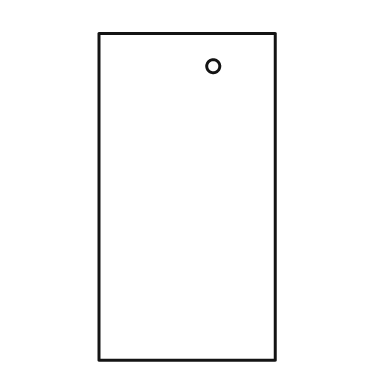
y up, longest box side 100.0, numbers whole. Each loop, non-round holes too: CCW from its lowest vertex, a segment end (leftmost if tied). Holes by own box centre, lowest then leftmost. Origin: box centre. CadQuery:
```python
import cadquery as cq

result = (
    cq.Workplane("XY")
    .moveTo(-27.0, -50.0)
    .lineTo(27.0, -50.0)
    .lineTo(27.0, 50.0)
    .lineTo(-27.0, 50.0)
    .close()
    .moveTo(8.0, 40.0)
    .circle(2.0)
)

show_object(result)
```